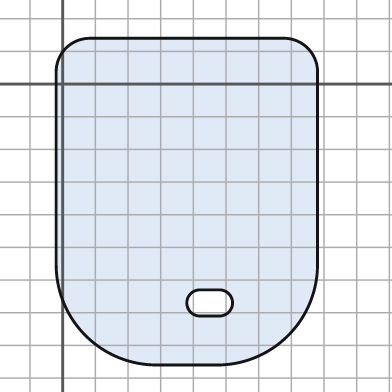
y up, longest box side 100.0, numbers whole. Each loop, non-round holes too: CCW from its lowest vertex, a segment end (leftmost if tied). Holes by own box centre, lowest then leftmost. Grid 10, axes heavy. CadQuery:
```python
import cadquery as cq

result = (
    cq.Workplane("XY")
    .moveTo(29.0, -86.0)
    .lineTo(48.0, -86.0)
    .threePointArc((69.0, -77.0), (78.0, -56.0))
    .lineTo(78.0, 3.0)
    .threePointArc((75.0, 11.0), (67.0, 14.0))
    .lineTo(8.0, 14.0)
    .threePointArc((1.0, 11.0), (-2.0, 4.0))
    .lineTo(-2.0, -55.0)
    .threePointArc((7.0, -77.0), (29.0, -86.0))
    .close()
    .moveTo(42.0, -71.0)
    .lineTo(48.0, -71.0)
    .threePointArc((52.0, -67.0), (48.0, -63.0))
    .lineTo(42.0, -63.0)
    .threePointArc((38.0, -67.0), (42.0, -71.0))
    .close()
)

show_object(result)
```